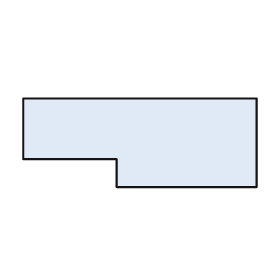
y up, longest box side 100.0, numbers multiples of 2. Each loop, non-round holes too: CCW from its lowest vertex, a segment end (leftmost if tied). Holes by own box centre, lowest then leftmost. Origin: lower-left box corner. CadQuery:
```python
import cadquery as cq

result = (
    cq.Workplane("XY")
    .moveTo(40.0, 0.0)
    .lineTo(100.0, 0.0)
    .lineTo(100.0, 38.0)
    .lineTo(0.0, 38.0)
    .lineTo(0.0, 12.0)
    .lineTo(40.0, 12.0)
    .close()
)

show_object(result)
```